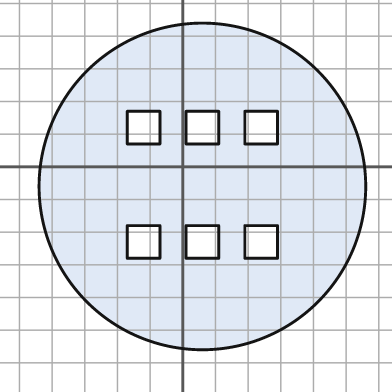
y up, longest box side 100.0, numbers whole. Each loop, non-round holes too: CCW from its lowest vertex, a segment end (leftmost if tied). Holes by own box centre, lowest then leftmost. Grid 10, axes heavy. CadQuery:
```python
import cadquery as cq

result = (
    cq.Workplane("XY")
    .moveTo(6.0, -6.0)
    .circle(50.0)
    .moveTo(-17.0, -28.0)
    .lineTo(-7.0, -28.0)
    .lineTo(-7.0, -18.0)
    .lineTo(-17.0, -18.0)
    .close()
    .moveTo(1.0, -28.0)
    .lineTo(11.0, -28.0)
    .lineTo(11.0, -18.0)
    .lineTo(1.0, -18.0)
    .close()
    .moveTo(19.0, -28.0)
    .lineTo(29.0, -28.0)
    .lineTo(29.0, -18.0)
    .lineTo(19.0, -18.0)
    .close()
    .moveTo(-17.0, 7.0)
    .lineTo(-7.0, 7.0)
    .lineTo(-7.0, 17.0)
    .lineTo(-17.0, 17.0)
    .close()
    .moveTo(1.0, 7.0)
    .lineTo(11.0, 7.0)
    .lineTo(11.0, 17.0)
    .lineTo(1.0, 17.0)
    .close()
    .moveTo(19.0, 7.0)
    .lineTo(29.0, 7.0)
    .lineTo(29.0, 17.0)
    .lineTo(19.0, 17.0)
    .close()
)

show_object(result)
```